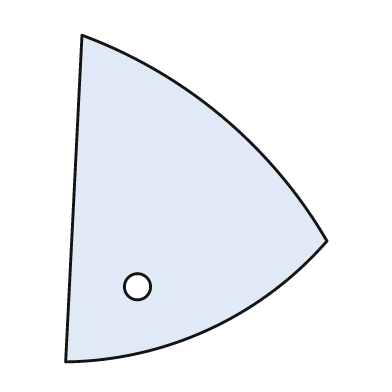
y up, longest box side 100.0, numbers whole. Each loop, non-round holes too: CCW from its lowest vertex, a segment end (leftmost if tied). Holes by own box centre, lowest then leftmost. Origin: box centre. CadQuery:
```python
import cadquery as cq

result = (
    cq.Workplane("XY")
    .moveTo(-40.0, -50.0)
    .threePointArc((4.0, -40.0), (40.0, -13.0))
    .threePointArc((8.0, 25.0), (-35.0, 50.0))
    .close()
    .moveTo(-18.0, -27.0)
    .circle(4.0)
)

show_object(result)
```